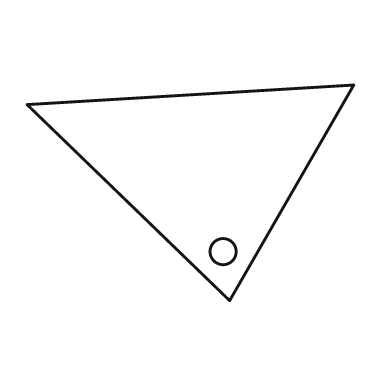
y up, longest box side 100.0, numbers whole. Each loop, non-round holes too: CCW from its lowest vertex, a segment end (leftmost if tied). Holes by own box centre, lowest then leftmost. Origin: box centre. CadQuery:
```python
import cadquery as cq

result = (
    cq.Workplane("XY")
    .moveTo(12.0, -33.0)
    .lineTo(50.0, 33.0)
    .lineTo(-50.0, 27.0)
    .close()
    .moveTo(10.0, -18.0)
    .circle(4.0)
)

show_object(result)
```